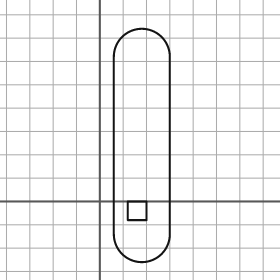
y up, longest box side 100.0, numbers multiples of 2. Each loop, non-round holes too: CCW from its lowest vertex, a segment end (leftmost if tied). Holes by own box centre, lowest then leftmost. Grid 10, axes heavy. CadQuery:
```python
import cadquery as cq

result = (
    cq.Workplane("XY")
    .moveTo(6.0, -14.0)
    .threePointArc((18.0, -26.0), (30.0, -14.0))
    .lineTo(30.0, 62.0)
    .threePointArc((18.0, 74.0), (6.0, 62.0))
    .close()
    .moveTo(12.0, -8.0)
    .lineTo(20.0, -8.0)
    .lineTo(20.0, 0.0)
    .lineTo(12.0, 0.0)
    .close()
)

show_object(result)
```